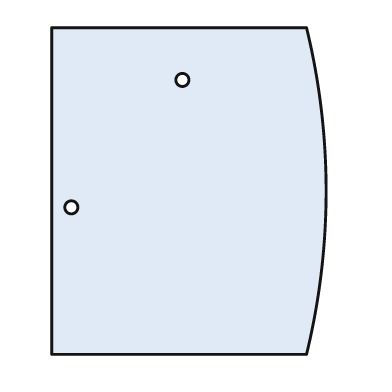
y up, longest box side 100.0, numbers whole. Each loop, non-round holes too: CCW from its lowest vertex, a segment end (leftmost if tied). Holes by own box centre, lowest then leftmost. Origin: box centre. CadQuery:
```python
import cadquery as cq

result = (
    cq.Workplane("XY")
    .moveTo(-42.0, -50.0)
    .lineTo(36.0, -50.0)
    .threePointArc((42.0, 0.0), (36.0, 50.0))
    .lineTo(-42.0, 50.0)
    .close()
    .moveTo(-36.0, -5.0)
    .circle(2.0)
    .moveTo(-2.0, 34.0)
    .circle(2.0)
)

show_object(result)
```